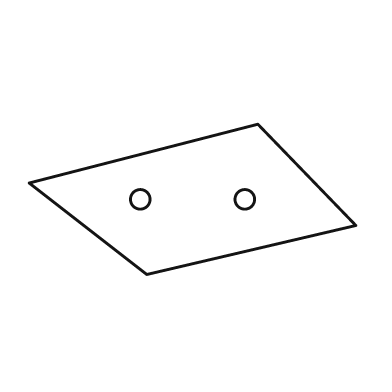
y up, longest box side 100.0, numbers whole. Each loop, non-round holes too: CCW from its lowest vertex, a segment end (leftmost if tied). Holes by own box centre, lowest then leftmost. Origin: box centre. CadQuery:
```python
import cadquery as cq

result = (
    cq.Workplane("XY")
    .moveTo(-14.0, -23.0)
    .lineTo(50.0, -8.0)
    .lineTo(20.0, 23.0)
    .lineTo(-50.0, 5.0)
    .close()
    .moveTo(-16.0, 0.0)
    .circle(3.0)
    .moveTo(16.0, 0.0)
    .circle(3.0)
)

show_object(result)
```